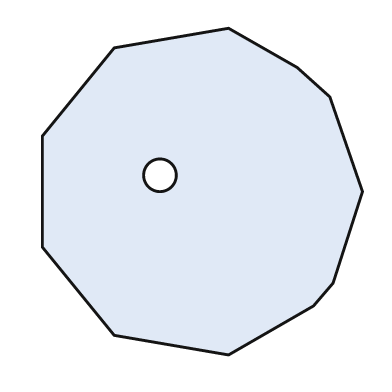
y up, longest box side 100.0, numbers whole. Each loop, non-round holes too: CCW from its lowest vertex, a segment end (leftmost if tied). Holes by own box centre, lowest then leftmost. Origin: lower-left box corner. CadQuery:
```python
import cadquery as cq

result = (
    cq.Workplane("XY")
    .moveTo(57.0, 0.0)
    .lineTo(83.0, 15.0)
    .lineTo(89.0, 22.0)
    .lineTo(98.0, 50.0)
    .lineTo(88.0, 79.0)
    .lineTo(78.0, 88.0)
    .lineTo(57.0, 100.0)
    .lineTo(22.0, 94.0)
    .lineTo(0.0, 67.0)
    .lineTo(0.0, 33.0)
    .lineTo(22.0, 6.0)
    .close()
    .moveTo(36.0, 55.0)
    .circle(5.0)
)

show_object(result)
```